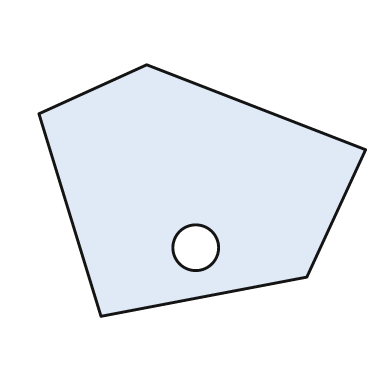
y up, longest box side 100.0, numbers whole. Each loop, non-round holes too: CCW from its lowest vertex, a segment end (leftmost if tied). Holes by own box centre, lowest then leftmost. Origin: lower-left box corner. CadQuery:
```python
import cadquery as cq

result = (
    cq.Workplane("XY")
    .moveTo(19.0, 0.0)
    .lineTo(82.0, 12.0)
    .lineTo(100.0, 51.0)
    .lineTo(33.0, 77.0)
    .lineTo(0.0, 62.0)
    .close()
    .moveTo(48.0, 21.0)
    .circle(7.0)
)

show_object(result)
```